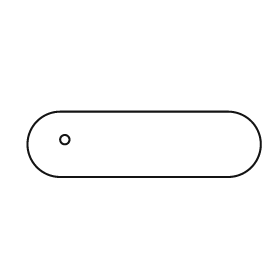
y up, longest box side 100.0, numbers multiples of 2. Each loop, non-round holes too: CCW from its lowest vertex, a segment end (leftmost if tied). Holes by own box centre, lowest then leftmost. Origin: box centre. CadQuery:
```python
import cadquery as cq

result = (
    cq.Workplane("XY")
    .moveTo(-36.0, -14.0)
    .lineTo(36.0, -14.0)
    .threePointArc((50.0, 0.0), (36.0, 14.0))
    .lineTo(-36.0, 14.0)
    .threePointArc((-50.0, 0.0), (-36.0, -14.0))
    .close()
    .moveTo(-34.0, 2.0)
    .circle(2.0)
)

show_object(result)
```